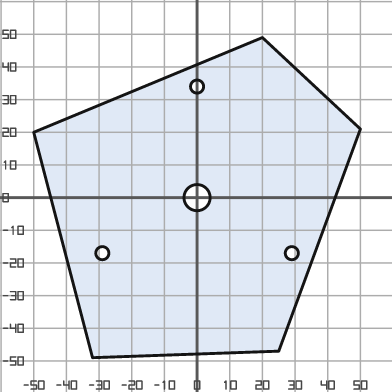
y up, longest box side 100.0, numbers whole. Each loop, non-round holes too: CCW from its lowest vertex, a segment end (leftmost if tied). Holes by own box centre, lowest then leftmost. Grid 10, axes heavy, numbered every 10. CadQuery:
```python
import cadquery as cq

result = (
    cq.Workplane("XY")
    .moveTo(-32.0, -49.0)
    .lineTo(25.0, -47.0)
    .lineTo(50.0, 21.0)
    .lineTo(20.0, 49.0)
    .lineTo(-50.0, 20.0)
    .close()
    .moveTo(-29.0, -17.0)
    .circle(2.0)
    .moveTo(29.0, -17.0)
    .circle(2.0)
    .moveTo(0.0, 0.0)
    .circle(4.0)
    .moveTo(0.0, 34.0)
    .circle(2.0)
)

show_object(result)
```